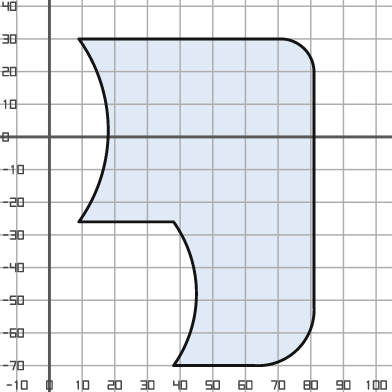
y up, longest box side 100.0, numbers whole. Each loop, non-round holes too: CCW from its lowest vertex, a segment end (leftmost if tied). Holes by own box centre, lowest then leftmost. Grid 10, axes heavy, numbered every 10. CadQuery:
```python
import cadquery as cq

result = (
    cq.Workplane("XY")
    .moveTo(38.0, -70.0)
    .lineTo(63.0, -70.0)
    .threePointArc((76.0, -65.0), (81.0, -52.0))
    .lineTo(81.0, 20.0)
    .threePointArc((78.0, 27.0), (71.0, 30.0))
    .lineTo(9.0, 30.0)
    .threePointArc((18.0, 2.0), (9.0, -26.0))
    .lineTo(38.0, -26.0)
    .threePointArc((45.0, -48.0), (38.0, -70.0))
    .close()
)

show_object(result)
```